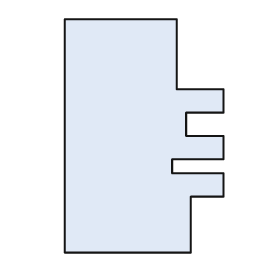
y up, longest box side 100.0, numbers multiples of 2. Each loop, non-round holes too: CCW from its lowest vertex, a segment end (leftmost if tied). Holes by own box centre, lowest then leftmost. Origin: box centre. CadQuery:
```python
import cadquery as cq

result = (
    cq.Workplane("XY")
    .moveTo(-34.0, -50.0)
    .lineTo(20.0, -50.0)
    .lineTo(20.0, -26.0)
    .lineTo(34.0, -26.0)
    .lineTo(34.0, -16.0)
    .lineTo(12.0, -16.0)
    .lineTo(12.0, -10.0)
    .lineTo(34.0, -10.0)
    .lineTo(34.0, 0.0)
    .lineTo(18.0, 0.0)
    .lineTo(18.0, 10.0)
    .lineTo(34.0, 10.0)
    .lineTo(34.0, 20.0)
    .lineTo(14.0, 20.0)
    .lineTo(14.0, 50.0)
    .lineTo(-34.0, 50.0)
    .close()
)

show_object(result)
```